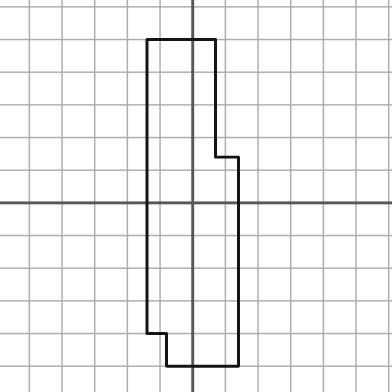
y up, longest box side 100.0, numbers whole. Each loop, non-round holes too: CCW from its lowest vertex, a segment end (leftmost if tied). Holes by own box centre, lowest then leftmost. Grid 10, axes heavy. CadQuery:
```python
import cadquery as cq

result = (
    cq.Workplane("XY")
    .moveTo(-8.0, -50.0)
    .lineTo(14.0, -50.0)
    .lineTo(14.0, 14.0)
    .lineTo(7.0, 14.0)
    .lineTo(7.0, 50.0)
    .lineTo(-14.0, 50.0)
    .lineTo(-14.0, -40.0)
    .lineTo(-8.0, -40.0)
    .close()
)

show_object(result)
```